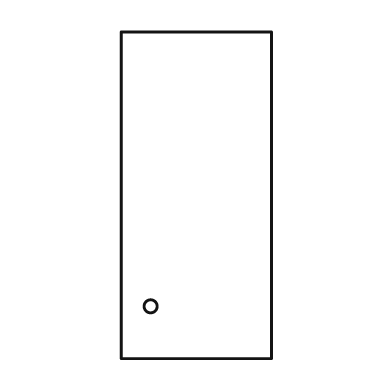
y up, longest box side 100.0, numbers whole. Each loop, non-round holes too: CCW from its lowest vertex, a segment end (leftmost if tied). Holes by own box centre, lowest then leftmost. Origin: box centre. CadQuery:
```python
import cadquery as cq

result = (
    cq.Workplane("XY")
    .moveTo(-23.0, -50.0)
    .lineTo(23.0, -50.0)
    .lineTo(23.0, 50.0)
    .lineTo(-23.0, 50.0)
    .close()
    .moveTo(-14.0, -34.0)
    .circle(2.0)
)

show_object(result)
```